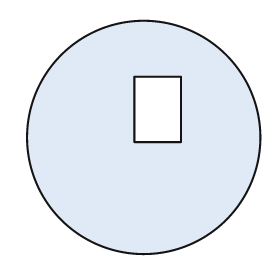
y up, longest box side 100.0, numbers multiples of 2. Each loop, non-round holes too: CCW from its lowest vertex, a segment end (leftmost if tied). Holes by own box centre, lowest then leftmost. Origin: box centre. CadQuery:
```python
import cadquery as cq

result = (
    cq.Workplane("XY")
    .moveTo(0.0, 0.0)
    .circle(50.0)
    .moveTo(-4.0, -2.0)
    .lineTo(16.0, -2.0)
    .lineTo(16.0, 26.0)
    .lineTo(-4.0, 26.0)
    .close()
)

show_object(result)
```